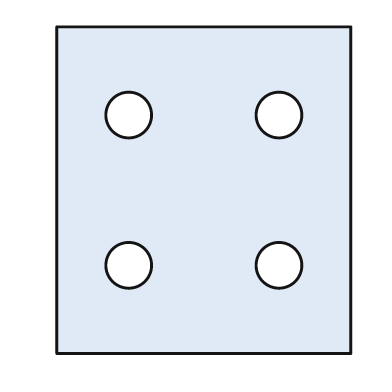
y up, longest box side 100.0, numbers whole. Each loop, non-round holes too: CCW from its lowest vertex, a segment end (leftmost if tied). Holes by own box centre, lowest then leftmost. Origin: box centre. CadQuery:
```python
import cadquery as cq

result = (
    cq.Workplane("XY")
    .moveTo(-45.0, -50.0)
    .lineTo(45.0, -50.0)
    .lineTo(45.0, 50.0)
    .lineTo(-45.0, 50.0)
    .close()
    .moveTo(-23.0, -23.0)
    .circle(7.0)
    .moveTo(23.0, -23.0)
    .circle(7.0)
    .moveTo(-23.0, 23.0)
    .circle(7.0)
    .moveTo(23.0, 23.0)
    .circle(7.0)
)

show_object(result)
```